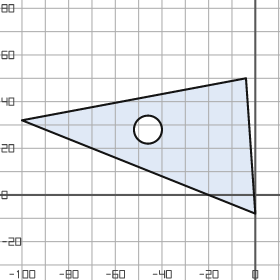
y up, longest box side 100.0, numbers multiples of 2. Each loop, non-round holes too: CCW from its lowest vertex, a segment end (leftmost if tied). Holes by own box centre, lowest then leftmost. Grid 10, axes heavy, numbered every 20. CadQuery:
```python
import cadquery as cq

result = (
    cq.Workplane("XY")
    .moveTo(0.0, -8.0)
    .lineTo(-4.0, 50.0)
    .lineTo(-100.0, 32.0)
    .close()
    .moveTo(-46.0, 28.0)
    .circle(6.0)
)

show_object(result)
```